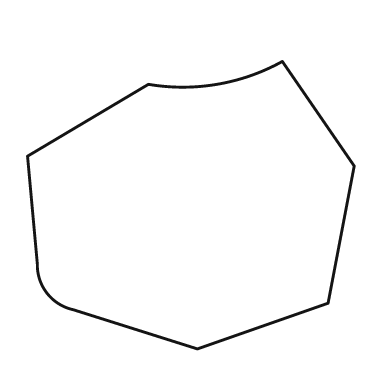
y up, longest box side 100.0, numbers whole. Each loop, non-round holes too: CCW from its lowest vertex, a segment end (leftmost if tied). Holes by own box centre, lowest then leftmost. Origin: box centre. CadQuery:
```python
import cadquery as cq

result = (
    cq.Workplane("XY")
    .moveTo(2.0, -44.0)
    .lineTo(42.0, -30.0)
    .lineTo(50.0, 12.0)
    .lineTo(28.0, 44.0)
    .threePointArc((8.0, 37.0), (-13.0, 37.0))
    .lineTo(-50.0, 15.0)
    .lineTo(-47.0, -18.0)
    .threePointArc((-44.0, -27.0), (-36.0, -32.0))
    .close()
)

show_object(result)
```